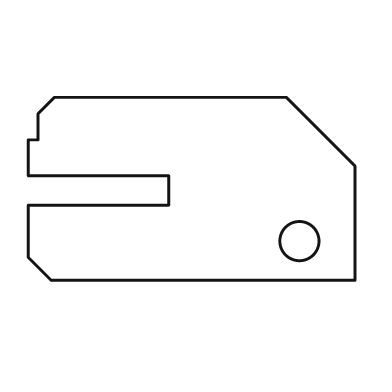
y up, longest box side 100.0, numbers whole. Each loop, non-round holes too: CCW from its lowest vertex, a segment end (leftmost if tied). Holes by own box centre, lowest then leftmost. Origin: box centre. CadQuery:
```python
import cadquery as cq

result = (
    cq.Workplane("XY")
    .moveTo(-43.0, -28.0)
    .lineTo(50.0, -28.0)
    .lineTo(50.0, 7.0)
    .lineTo(29.0, 28.0)
    .lineTo(-42.0, 28.0)
    .lineTo(-47.0, 23.0)
    .lineTo(-47.0, 15.0)
    .lineTo(-50.0, 15.0)
    .lineTo(-50.0, 4.0)
    .lineTo(-7.0, 4.0)
    .lineTo(-7.0, -5.0)
    .lineTo(-50.0, -5.0)
    .lineTo(-50.0, -21.0)
    .close()
    .moveTo(33.0, -16.0)
    .circle(6.0)
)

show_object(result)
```